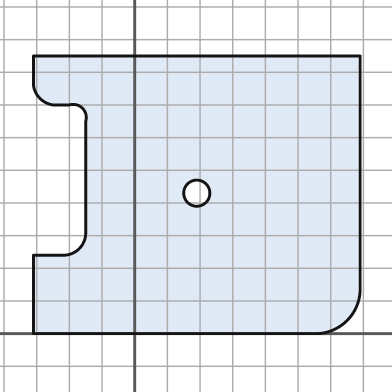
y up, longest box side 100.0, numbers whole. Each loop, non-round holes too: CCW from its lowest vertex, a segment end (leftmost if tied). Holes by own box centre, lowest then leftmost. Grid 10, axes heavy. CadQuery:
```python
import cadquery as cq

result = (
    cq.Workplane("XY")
    .moveTo(-31.0, 0.0)
    .lineTo(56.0, 0.0)
    .threePointArc((65.0, 4.0), (69.0, 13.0))
    .lineTo(69.0, 85.0)
    .lineTo(-31.0, 85.0)
    .lineTo(-31.0, 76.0)
    .threePointArc((-29.0, 72.0), (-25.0, 70.0))
    .lineTo(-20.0, 70.0)
    .threePointArc((-16.0, 69.0), (-15.0, 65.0))
    .lineTo(-15.0, 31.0)
    .threePointArc((-17.0, 26.0), (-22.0, 24.0))
    .lineTo(-31.0, 24.0)
    .close()
    .moveTo(19.0, 43.0)
    .circle(4.0)
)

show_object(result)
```